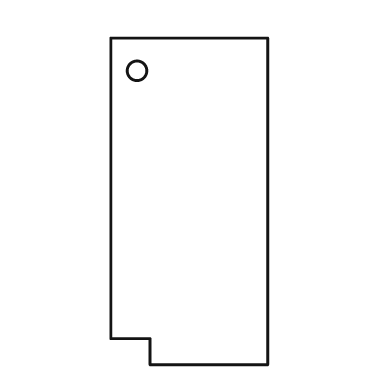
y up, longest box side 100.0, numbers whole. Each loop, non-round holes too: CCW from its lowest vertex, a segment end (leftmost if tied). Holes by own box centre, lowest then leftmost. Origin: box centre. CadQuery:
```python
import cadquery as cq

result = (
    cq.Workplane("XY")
    .moveTo(-12.0, -50.0)
    .lineTo(24.0, -50.0)
    .lineTo(24.0, 50.0)
    .lineTo(-24.0, 50.0)
    .lineTo(-24.0, -42.0)
    .lineTo(-12.0, -42.0)
    .close()
    .moveTo(-16.0, 40.0)
    .circle(3.0)
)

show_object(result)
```